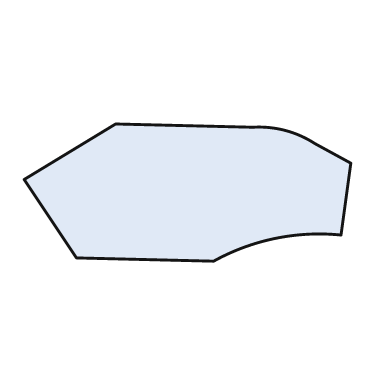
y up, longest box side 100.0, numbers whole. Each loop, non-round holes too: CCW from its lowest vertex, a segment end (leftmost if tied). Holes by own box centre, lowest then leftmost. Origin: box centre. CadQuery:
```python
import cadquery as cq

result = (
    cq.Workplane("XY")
    .moveTo(8.0, -21.0)
    .threePointArc((27.0, -14.0), (47.0, -13.0))
    .lineTo(50.0, 9.0)
    .lineTo(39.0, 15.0)
    .threePointArc((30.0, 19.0), (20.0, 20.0))
    .lineTo(-22.0, 21.0)
    .lineTo(-50.0, 4.0)
    .lineTo(-34.0, -20.0)
    .close()
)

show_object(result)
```